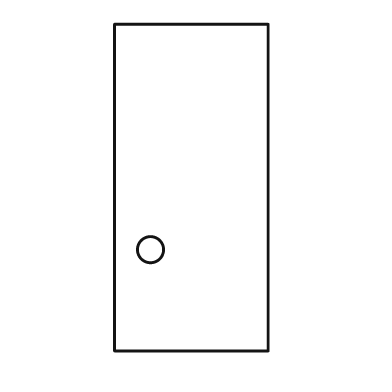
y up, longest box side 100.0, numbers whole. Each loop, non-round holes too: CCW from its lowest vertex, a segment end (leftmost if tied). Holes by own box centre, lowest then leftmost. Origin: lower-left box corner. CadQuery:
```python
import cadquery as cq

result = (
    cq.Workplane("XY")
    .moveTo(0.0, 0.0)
    .lineTo(47.0, 0.0)
    .lineTo(47.0, 100.0)
    .lineTo(0.0, 100.0)
    .close()
    .moveTo(11.0, 31.0)
    .circle(4.0)
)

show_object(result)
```